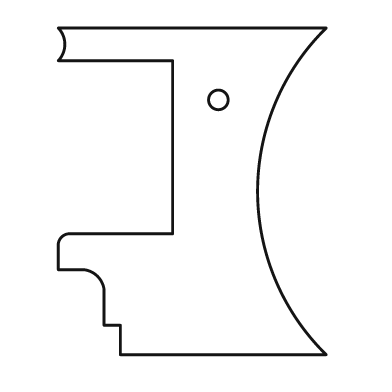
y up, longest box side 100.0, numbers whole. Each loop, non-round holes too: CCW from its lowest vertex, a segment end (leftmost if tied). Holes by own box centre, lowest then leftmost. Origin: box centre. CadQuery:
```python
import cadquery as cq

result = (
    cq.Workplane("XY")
    .moveTo(-22.0, -50.0)
    .lineTo(41.0, -50.0)
    .threePointArc((20.0, 0.0), (41.0, 50.0))
    .lineTo(-41.0, 50.0)
    .threePointArc((-39.0, 45.0), (-41.0, 40.0))
    .lineTo(-6.0, 40.0)
    .lineTo(-6.0, -13.0)
    .lineTo(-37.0, -13.0)
    .threePointArc((-40.0, -14.0), (-41.0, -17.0))
    .lineTo(-41.0, -24.0)
    .lineTo(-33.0, -24.0)
    .threePointArc((-29.0, -26.0), (-27.0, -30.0))
    .lineTo(-27.0, -41.0)
    .lineTo(-22.0, -41.0)
    .close()
    .moveTo(8.0, 28.0)
    .circle(3.0)
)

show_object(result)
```